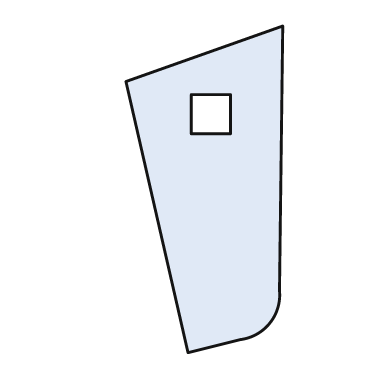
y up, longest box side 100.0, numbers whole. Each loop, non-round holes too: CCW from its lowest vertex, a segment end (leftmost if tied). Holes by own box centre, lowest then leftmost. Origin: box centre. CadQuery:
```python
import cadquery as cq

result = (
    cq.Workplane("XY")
    .moveTo(-5.0, -50.0)
    .lineTo(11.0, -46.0)
    .threePointArc((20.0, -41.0), (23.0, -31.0))
    .lineTo(24.0, 50.0)
    .lineTo(-24.0, 33.0)
    .close()
    .moveTo(-4.0, 17.0)
    .lineTo(8.0, 17.0)
    .lineTo(8.0, 29.0)
    .lineTo(-4.0, 29.0)
    .close()
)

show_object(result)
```